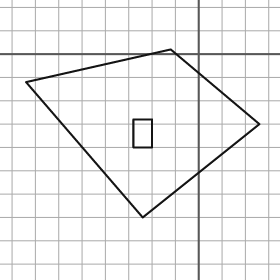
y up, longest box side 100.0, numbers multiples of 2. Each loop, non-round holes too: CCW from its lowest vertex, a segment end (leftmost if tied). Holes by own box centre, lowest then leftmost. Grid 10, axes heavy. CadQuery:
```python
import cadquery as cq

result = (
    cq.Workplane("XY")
    .moveTo(-24.0, -70.0)
    .lineTo(26.0, -30.0)
    .lineTo(-12.0, 2.0)
    .lineTo(-74.0, -12.0)
    .close()
    .moveTo(-28.0, -40.0)
    .lineTo(-20.0, -40.0)
    .lineTo(-20.0, -28.0)
    .lineTo(-28.0, -28.0)
    .close()
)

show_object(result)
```